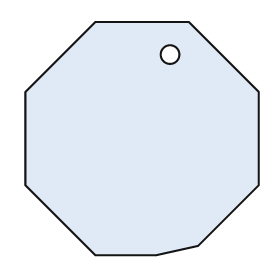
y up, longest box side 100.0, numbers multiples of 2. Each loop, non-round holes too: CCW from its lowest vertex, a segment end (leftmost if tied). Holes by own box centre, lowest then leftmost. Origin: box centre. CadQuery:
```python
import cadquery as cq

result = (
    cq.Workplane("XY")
    .moveTo(-20.0, -50.0)
    .lineTo(6.0, -50.0)
    .lineTo(24.0, -46.0)
    .lineTo(50.0, -20.0)
    .lineTo(50.0, 20.0)
    .lineTo(20.0, 50.0)
    .lineTo(-20.0, 50.0)
    .lineTo(-50.0, 20.0)
    .lineTo(-50.0, -20.0)
    .close()
    .moveTo(12.0, 36.0)
    .circle(4.0)
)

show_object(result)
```